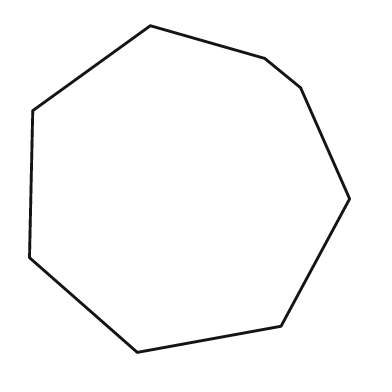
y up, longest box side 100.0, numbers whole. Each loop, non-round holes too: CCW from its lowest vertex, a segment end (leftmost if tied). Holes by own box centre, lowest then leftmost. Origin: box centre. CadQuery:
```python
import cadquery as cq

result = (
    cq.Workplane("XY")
    .moveTo(-16.0, -50.0)
    .lineTo(28.0, -42.0)
    .lineTo(49.0, -3.0)
    .lineTo(34.0, 31.0)
    .lineTo(23.0, 40.0)
    .lineTo(-12.0, 50.0)
    .lineTo(-48.0, 24.0)
    .lineTo(-49.0, -21.0)
    .close()
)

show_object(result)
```